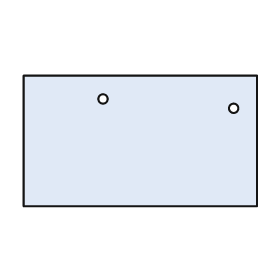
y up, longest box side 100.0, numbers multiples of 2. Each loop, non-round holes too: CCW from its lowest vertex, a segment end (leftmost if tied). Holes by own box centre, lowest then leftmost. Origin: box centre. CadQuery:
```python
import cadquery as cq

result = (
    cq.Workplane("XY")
    .moveTo(-50.0, -28.0)
    .lineTo(50.0, -28.0)
    .lineTo(50.0, 28.0)
    .lineTo(-50.0, 28.0)
    .close()
    .moveTo(40.0, 14.0)
    .circle(2.0)
    .moveTo(-16.0, 18.0)
    .circle(2.0)
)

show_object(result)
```